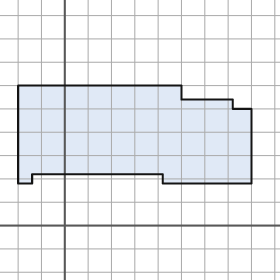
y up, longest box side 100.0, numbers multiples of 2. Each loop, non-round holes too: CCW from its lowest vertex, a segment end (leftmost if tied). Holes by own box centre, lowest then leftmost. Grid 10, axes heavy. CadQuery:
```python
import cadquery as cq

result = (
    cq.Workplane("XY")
    .moveTo(-20.0, 18.0)
    .lineTo(-14.0, 18.0)
    .lineTo(-14.0, 22.0)
    .lineTo(42.0, 22.0)
    .lineTo(42.0, 18.0)
    .lineTo(80.0, 18.0)
    .lineTo(80.0, 50.0)
    .lineTo(72.0, 50.0)
    .lineTo(72.0, 54.0)
    .lineTo(50.0, 54.0)
    .lineTo(50.0, 60.0)
    .lineTo(-20.0, 60.0)
    .close()
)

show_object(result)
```